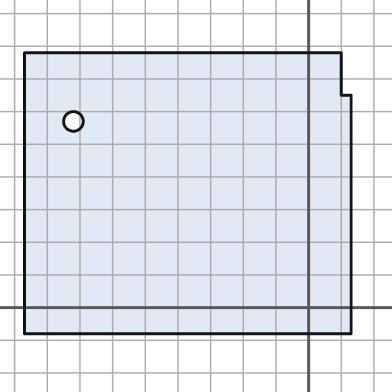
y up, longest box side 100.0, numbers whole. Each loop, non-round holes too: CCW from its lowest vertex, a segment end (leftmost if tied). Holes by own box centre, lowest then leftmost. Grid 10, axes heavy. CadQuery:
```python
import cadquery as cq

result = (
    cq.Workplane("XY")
    .moveTo(-87.0, -8.0)
    .lineTo(13.0, -8.0)
    .lineTo(13.0, 65.0)
    .lineTo(10.0, 65.0)
    .lineTo(10.0, 78.0)
    .lineTo(-87.0, 78.0)
    .close()
    .moveTo(-72.0, 57.0)
    .circle(3.0)
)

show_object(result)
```